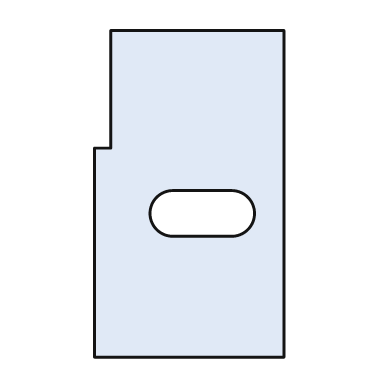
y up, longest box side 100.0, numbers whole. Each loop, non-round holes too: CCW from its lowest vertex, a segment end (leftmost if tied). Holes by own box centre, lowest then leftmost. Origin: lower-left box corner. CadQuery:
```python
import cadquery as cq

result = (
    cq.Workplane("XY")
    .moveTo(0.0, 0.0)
    .lineTo(58.0, 0.0)
    .lineTo(58.0, 100.0)
    .lineTo(5.0, 100.0)
    .lineTo(5.0, 64.0)
    .lineTo(0.0, 64.0)
    .close()
    .moveTo(24.0, 37.0)
    .lineTo(42.0, 37.0)
    .threePointArc((49.0, 44.0), (42.0, 51.0))
    .lineTo(24.0, 51.0)
    .threePointArc((17.0, 44.0), (24.0, 37.0))
    .close()
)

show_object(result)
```